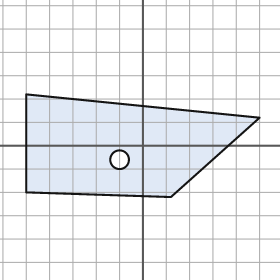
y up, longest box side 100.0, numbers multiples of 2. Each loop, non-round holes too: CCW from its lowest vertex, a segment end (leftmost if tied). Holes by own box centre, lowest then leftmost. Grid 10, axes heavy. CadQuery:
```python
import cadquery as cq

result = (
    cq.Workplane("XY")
    .moveTo(12.0, -22.0)
    .lineTo(50.0, 12.0)
    .lineTo(-50.0, 22.0)
    .lineTo(-50.0, -20.0)
    .close()
    .moveTo(-10.0, -6.0)
    .circle(4.0)
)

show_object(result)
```